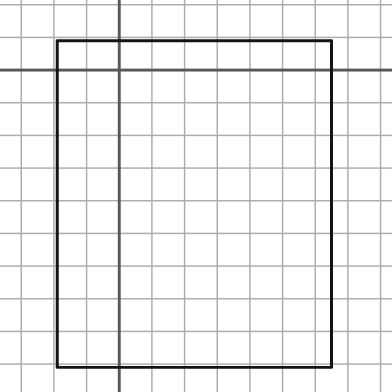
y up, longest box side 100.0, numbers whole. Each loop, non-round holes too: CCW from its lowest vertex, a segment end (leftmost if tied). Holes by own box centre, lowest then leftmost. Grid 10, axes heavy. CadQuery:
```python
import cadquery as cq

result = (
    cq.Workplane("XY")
    .moveTo(-19.0, -91.0)
    .lineTo(65.0, -91.0)
    .lineTo(65.0, 9.0)
    .lineTo(-19.0, 9.0)
    .close()
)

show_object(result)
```